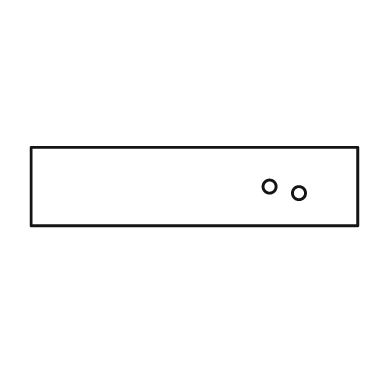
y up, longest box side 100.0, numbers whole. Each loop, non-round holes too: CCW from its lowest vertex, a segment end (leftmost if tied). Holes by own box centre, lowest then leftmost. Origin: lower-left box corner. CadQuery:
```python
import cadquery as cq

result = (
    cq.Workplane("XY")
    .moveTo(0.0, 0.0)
    .lineTo(100.0, 0.0)
    .lineTo(100.0, 24.0)
    .lineTo(0.0, 24.0)
    .close()
    .moveTo(82.0, 10.0)
    .circle(2.0)
    .moveTo(73.0, 12.0)
    .circle(2.0)
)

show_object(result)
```